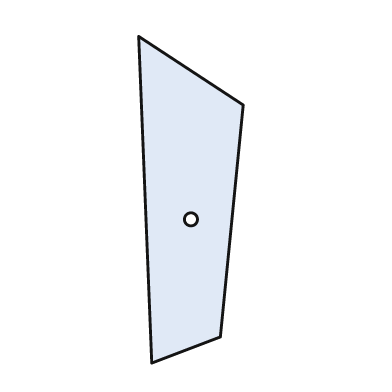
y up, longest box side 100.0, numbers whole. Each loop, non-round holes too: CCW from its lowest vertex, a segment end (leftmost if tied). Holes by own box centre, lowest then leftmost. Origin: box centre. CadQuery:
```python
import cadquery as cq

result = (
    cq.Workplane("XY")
    .moveTo(-12.0, -50.0)
    .lineTo(9.0, -42.0)
    .lineTo(16.0, 29.0)
    .lineTo(-16.0, 50.0)
    .close()
    .moveTo(0.0, -6.0)
    .circle(2.0)
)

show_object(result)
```